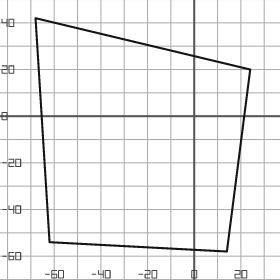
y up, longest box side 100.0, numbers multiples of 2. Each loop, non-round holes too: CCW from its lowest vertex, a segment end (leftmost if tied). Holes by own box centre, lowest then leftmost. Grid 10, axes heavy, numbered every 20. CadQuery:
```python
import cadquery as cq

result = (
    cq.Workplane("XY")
    .moveTo(14.0, -58.0)
    .lineTo(24.0, 20.0)
    .lineTo(-68.0, 42.0)
    .lineTo(-62.0, -54.0)
    .close()
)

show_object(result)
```